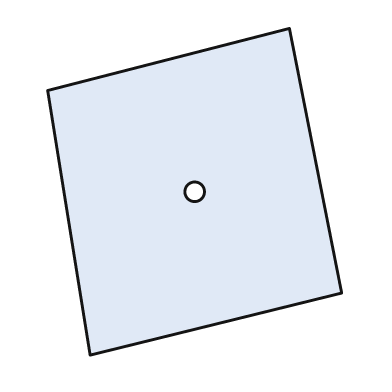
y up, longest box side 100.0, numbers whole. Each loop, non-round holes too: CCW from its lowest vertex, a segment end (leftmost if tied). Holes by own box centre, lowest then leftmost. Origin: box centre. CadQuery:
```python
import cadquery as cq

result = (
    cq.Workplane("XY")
    .moveTo(-32.0, -50.0)
    .lineTo(45.0, -31.0)
    .lineTo(29.0, 50.0)
    .lineTo(-45.0, 31.0)
    .close()
    .moveTo(0.0, 0.0)
    .circle(3.0)
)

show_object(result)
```